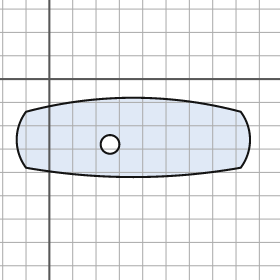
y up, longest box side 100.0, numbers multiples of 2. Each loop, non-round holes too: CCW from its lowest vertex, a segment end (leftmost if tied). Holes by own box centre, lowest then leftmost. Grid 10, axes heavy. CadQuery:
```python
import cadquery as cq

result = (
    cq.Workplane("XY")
    .moveTo(-10.0, -38.0)
    .threePointArc((36.0, -42.0), (82.0, -38.0))
    .threePointArc((86.0, -26.0), (82.0, -14.0))
    .threePointArc((36.0, -8.0), (-10.0, -14.0))
    .threePointArc((-14.0, -26.0), (-10.0, -38.0))
    .close()
    .moveTo(26.0, -28.0)
    .circle(4.0)
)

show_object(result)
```